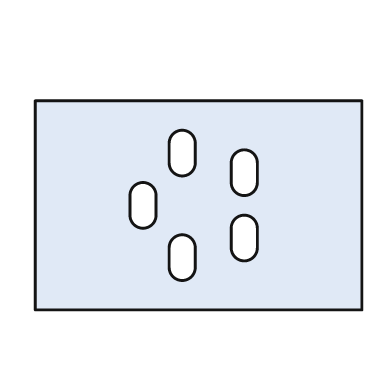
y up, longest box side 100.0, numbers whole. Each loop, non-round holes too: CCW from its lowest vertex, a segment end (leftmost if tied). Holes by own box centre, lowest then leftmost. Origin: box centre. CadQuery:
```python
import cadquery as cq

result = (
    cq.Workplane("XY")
    .moveTo(-50.0, -32.0)
    .lineTo(50.0, -32.0)
    .lineTo(50.0, 32.0)
    .lineTo(-50.0, 32.0)
    .close()
    .moveTo(-9.0, -19.0)
    .threePointArc((-5.0, -23.0), (-1.0, -19.0))
    .lineTo(-1.0, -13.0)
    .threePointArc((-5.0, -9.0), (-9.0, -13.0))
    .close()
    .moveTo(10.0, -13.0)
    .threePointArc((14.0, -17.0), (18.0, -13.0))
    .lineTo(18.0, -7.0)
    .threePointArc((14.0, -3.0), (10.0, -7.0))
    .close()
    .moveTo(-21.0, -3.0)
    .threePointArc((-17.0, -7.0), (-13.0, -3.0))
    .lineTo(-13.0, 3.0)
    .threePointArc((-17.0, 7.0), (-21.0, 3.0))
    .close()
    .moveTo(10.0, 7.0)
    .threePointArc((14.0, 3.0), (18.0, 7.0))
    .lineTo(18.0, 13.0)
    .threePointArc((14.0, 17.0), (10.0, 13.0))
    .close()
    .moveTo(-9.0, 13.0)
    .threePointArc((-5.0, 9.0), (-1.0, 13.0))
    .lineTo(-1.0, 19.0)
    .threePointArc((-5.0, 23.0), (-9.0, 19.0))
    .close()
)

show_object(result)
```